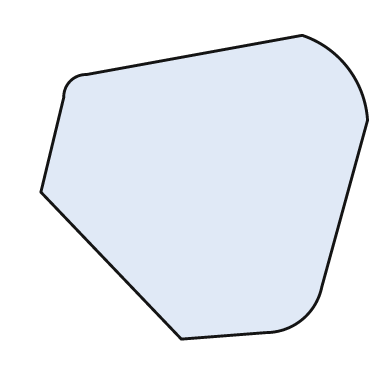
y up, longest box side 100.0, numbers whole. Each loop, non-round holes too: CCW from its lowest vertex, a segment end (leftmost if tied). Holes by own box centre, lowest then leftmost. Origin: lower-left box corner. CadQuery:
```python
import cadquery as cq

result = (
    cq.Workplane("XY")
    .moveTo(43.0, 0.0)
    .lineTo(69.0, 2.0)
    .threePointArc((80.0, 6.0), (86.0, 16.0))
    .lineTo(100.0, 67.0)
    .threePointArc((94.0, 83.0), (80.0, 93.0))
    .lineTo(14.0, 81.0)
    .threePointArc((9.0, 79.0), (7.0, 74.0))
    .lineTo(0.0, 45.0)
    .close()
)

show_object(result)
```